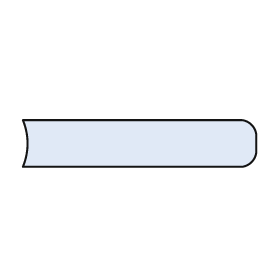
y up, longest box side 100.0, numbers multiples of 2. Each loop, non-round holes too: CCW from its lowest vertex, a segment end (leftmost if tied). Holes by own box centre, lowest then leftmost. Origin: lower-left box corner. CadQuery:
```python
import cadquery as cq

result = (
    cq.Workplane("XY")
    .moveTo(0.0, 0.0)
    .lineTo(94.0, 0.0)
    .threePointArc((98.0, 2.0), (100.0, 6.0))
    .lineTo(100.0, 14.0)
    .threePointArc((98.0, 18.0), (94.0, 20.0))
    .lineTo(0.0, 20.0)
    .threePointArc((2.0, 10.0), (0.0, 0.0))
    .close()
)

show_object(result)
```